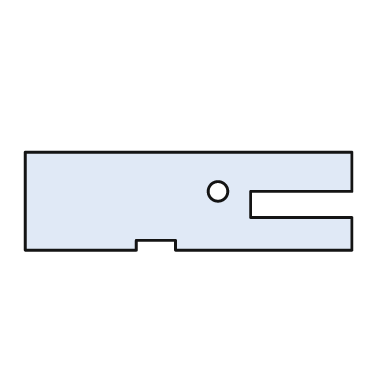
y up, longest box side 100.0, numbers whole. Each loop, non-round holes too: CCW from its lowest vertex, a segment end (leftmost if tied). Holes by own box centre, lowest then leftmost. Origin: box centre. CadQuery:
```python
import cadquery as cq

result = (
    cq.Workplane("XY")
    .moveTo(-50.0, -15.0)
    .lineTo(-16.0, -15.0)
    .lineTo(-16.0, -12.0)
    .lineTo(-4.0, -12.0)
    .lineTo(-4.0, -15.0)
    .lineTo(50.0, -15.0)
    .lineTo(50.0, -5.0)
    .lineTo(19.0, -5.0)
    .lineTo(19.0, 3.0)
    .lineTo(50.0, 3.0)
    .lineTo(50.0, 15.0)
    .lineTo(-50.0, 15.0)
    .close()
    .moveTo(9.0, 3.0)
    .circle(3.0)
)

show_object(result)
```